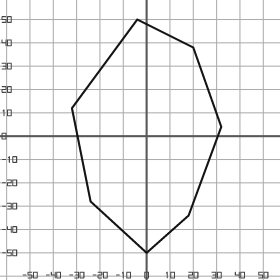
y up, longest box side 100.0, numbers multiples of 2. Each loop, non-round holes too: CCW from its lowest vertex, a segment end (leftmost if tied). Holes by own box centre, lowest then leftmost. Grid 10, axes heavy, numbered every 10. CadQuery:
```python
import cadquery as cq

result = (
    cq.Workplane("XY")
    .moveTo(0.0, -50.0)
    .lineTo(18.0, -34.0)
    .lineTo(32.0, 4.0)
    .lineTo(20.0, 38.0)
    .lineTo(-4.0, 50.0)
    .lineTo(-32.0, 12.0)
    .lineTo(-24.0, -28.0)
    .close()
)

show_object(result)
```